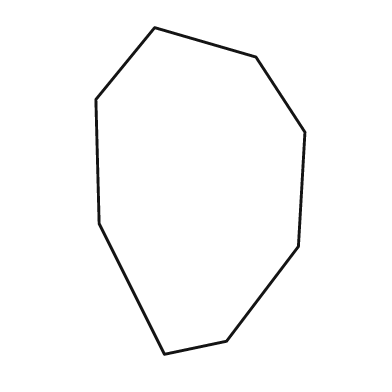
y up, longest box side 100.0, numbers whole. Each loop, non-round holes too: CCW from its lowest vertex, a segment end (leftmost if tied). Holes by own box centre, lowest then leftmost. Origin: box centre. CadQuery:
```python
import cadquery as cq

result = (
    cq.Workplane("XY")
    .moveTo(-11.0, -50.0)
    .lineTo(8.0, -46.0)
    .lineTo(30.0, -17.0)
    .lineTo(32.0, 18.0)
    .lineTo(17.0, 41.0)
    .lineTo(-14.0, 50.0)
    .lineTo(-32.0, 28.0)
    .lineTo(-31.0, -10.0)
    .close()
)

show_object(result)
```